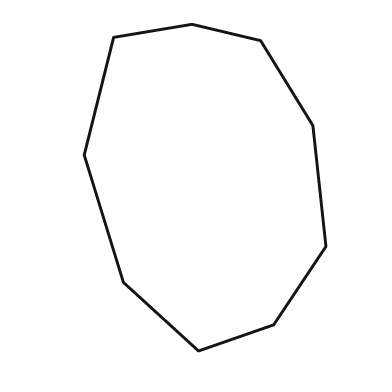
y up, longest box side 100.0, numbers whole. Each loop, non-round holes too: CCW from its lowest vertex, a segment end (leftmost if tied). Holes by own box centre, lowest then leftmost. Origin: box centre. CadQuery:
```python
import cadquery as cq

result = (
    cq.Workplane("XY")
    .moveTo(-2.0, -50.0)
    .lineTo(21.0, -42.0)
    .lineTo(37.0, -18.0)
    .lineTo(33.0, 19.0)
    .lineTo(17.0, 45.0)
    .lineTo(-4.0, 50.0)
    .lineTo(-28.0, 46.0)
    .lineTo(-37.0, 10.0)
    .lineTo(-25.0, -29.0)
    .close()
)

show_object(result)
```